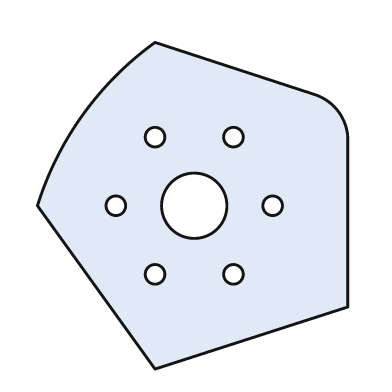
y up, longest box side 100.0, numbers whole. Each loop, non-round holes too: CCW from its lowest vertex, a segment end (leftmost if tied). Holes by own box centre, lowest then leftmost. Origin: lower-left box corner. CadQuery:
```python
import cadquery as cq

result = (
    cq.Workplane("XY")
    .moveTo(36.0, 0.0)
    .lineTo(95.0, 19.0)
    .lineTo(95.0, 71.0)
    .threePointArc((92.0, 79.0), (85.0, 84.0))
    .lineTo(36.0, 100.0)
    .threePointArc((14.0, 78.0), (0.0, 50.0))
    .close()
    .moveTo(36.0, 29.0)
    .circle(3.0)
    .moveTo(60.0, 29.0)
    .circle(3.0)
    .moveTo(24.0, 50.0)
    .circle(3.0)
    .moveTo(48.0, 50.0)
    .circle(10.0)
    .moveTo(72.0, 50.0)
    .circle(3.0)
    .moveTo(36.0, 71.0)
    .circle(3.0)
    .moveTo(60.0, 71.0)
    .circle(3.0)
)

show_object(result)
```